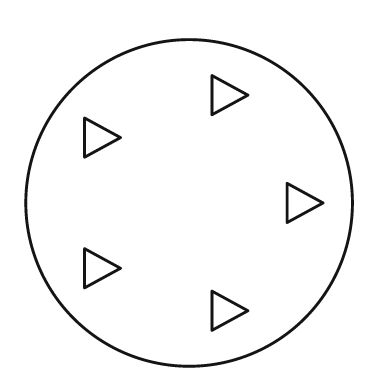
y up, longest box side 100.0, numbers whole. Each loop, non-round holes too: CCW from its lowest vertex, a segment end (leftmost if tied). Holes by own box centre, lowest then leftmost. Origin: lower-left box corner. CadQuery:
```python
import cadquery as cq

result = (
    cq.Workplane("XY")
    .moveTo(50.0, 50.0)
    .circle(50.0)
    .moveTo(57.0, 11.0)
    .lineTo(68.0, 17.0)
    .lineTo(57.0, 23.0)
    .close()
    .moveTo(18.0, 24.0)
    .lineTo(29.0, 30.0)
    .lineTo(18.0, 36.0)
    .close()
    .moveTo(80.0, 44.0)
    .lineTo(91.0, 50.0)
    .lineTo(80.0, 56.0)
    .close()
    .moveTo(18.0, 64.0)
    .lineTo(29.0, 70.0)
    .lineTo(18.0, 76.0)
    .close()
    .moveTo(57.0, 77.0)
    .lineTo(68.0, 83.0)
    .lineTo(57.0, 89.0)
    .close()
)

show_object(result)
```